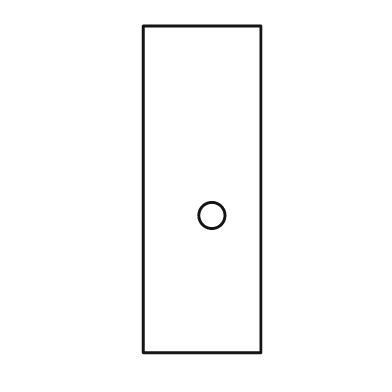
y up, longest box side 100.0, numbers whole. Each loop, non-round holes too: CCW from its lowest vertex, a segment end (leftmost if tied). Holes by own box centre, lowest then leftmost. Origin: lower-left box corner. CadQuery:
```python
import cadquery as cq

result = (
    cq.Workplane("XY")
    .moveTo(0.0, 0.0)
    .lineTo(36.0, 0.0)
    .lineTo(36.0, 100.0)
    .lineTo(0.0, 100.0)
    .close()
    .moveTo(21.0, 42.0)
    .circle(4.0)
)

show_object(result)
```